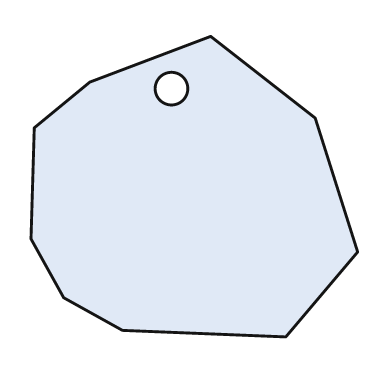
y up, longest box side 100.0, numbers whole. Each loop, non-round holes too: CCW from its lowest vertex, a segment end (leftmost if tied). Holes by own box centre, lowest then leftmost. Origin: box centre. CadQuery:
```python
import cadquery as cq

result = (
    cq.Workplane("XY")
    .moveTo(28.0, -46.0)
    .lineTo(50.0, -20.0)
    .lineTo(37.0, 21.0)
    .lineTo(5.0, 46.0)
    .lineTo(-32.0, 32.0)
    .lineTo(-49.0, 18.0)
    .lineTo(-50.0, -16.0)
    .lineTo(-40.0, -34.0)
    .lineTo(-22.0, -44.0)
    .close()
    .moveTo(-7.0, 30.0)
    .circle(5.0)
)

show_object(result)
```